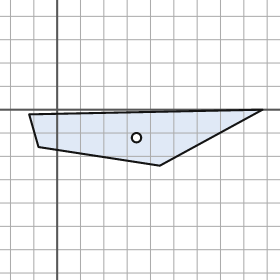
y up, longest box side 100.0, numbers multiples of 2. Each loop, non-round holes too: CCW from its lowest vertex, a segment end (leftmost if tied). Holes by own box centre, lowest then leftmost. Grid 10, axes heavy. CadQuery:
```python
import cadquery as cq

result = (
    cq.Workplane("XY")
    .moveTo(44.0, -24.0)
    .lineTo(88.0, 0.0)
    .lineTo(-12.0, -2.0)
    .lineTo(-8.0, -16.0)
    .close()
    .moveTo(34.0, -12.0)
    .circle(2.0)
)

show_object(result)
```